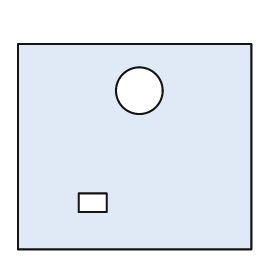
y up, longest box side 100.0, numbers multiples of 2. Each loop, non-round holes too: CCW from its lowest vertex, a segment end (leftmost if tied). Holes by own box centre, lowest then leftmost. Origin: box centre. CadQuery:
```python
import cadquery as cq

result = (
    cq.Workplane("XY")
    .moveTo(-50.0, -44.0)
    .lineTo(50.0, -44.0)
    .lineTo(50.0, 44.0)
    .lineTo(-50.0, 44.0)
    .close()
    .moveTo(-24.0, -28.0)
    .lineTo(-12.0, -28.0)
    .lineTo(-12.0, -20.0)
    .lineTo(-24.0, -20.0)
    .close()
    .moveTo(2.0, 24.0)
    .circle(10.0)
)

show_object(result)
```